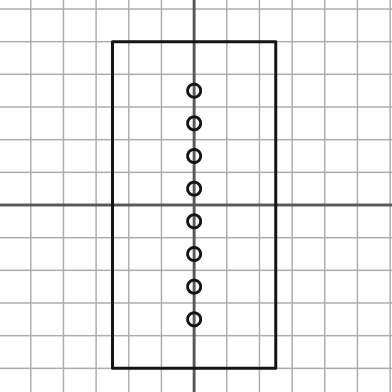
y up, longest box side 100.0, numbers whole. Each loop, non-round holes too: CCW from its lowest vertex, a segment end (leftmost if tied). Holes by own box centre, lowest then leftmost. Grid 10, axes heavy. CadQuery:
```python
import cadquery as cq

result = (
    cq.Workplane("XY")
    .moveTo(-25.0, -50.0)
    .lineTo(25.0, -50.0)
    .lineTo(25.0, 50.0)
    .lineTo(-25.0, 50.0)
    .close()
    .moveTo(0.0, -35.0)
    .circle(2.0)
    .moveTo(0.0, -25.0)
    .circle(2.0)
    .moveTo(0.0, -15.0)
    .circle(2.0)
    .moveTo(0.0, -5.0)
    .circle(2.0)
    .moveTo(0.0, 5.0)
    .circle(2.0)
    .moveTo(0.0, 15.0)
    .circle(2.0)
    .moveTo(0.0, 25.0)
    .circle(2.0)
    .moveTo(0.0, 35.0)
    .circle(2.0)
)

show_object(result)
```